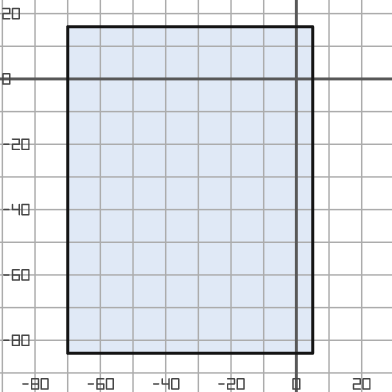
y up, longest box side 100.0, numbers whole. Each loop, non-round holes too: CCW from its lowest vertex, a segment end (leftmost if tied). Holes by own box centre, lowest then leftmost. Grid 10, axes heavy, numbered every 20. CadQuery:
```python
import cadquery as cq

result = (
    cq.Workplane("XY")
    .moveTo(-70.0, -84.0)
    .lineTo(5.0, -84.0)
    .lineTo(5.0, 16.0)
    .lineTo(-70.0, 16.0)
    .close()
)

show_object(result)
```